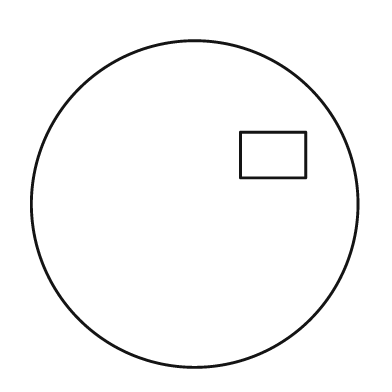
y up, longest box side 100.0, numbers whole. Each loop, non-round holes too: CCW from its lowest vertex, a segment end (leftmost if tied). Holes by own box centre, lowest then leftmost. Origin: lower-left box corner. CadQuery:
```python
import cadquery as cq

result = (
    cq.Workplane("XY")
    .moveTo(50.0, 50.0)
    .circle(50.0)
    .moveTo(64.0, 58.0)
    .lineTo(84.0, 58.0)
    .lineTo(84.0, 72.0)
    .lineTo(64.0, 72.0)
    .close()
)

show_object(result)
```